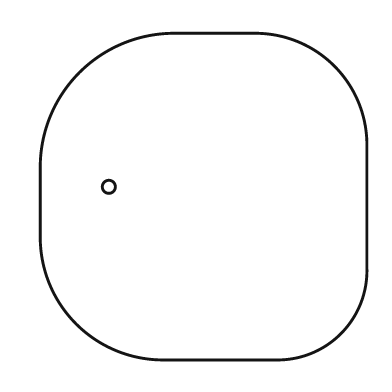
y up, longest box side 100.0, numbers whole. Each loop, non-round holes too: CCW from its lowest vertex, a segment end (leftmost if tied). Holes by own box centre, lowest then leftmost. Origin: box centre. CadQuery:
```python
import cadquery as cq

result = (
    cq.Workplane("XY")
    .moveTo(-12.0, -50.0)
    .lineTo(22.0, -50.0)
    .threePointArc((42.0, -42.0), (50.0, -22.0))
    .lineTo(50.0, 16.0)
    .threePointArc((40.0, 40.0), (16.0, 50.0))
    .lineTo(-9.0, 50.0)
    .threePointArc((-38.0, 38.0), (-50.0, 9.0))
    .lineTo(-50.0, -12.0)
    .threePointArc((-39.0, -39.0), (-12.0, -50.0))
    .close()
    .moveTo(-29.0, 3.0)
    .circle(2.0)
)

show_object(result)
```